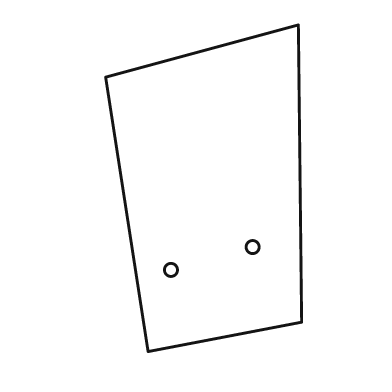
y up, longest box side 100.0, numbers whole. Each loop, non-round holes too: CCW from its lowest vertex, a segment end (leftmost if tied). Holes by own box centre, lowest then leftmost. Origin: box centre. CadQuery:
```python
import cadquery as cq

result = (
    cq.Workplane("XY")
    .moveTo(-17.0, -50.0)
    .lineTo(30.0, -41.0)
    .lineTo(29.0, 50.0)
    .lineTo(-30.0, 34.0)
    .close()
    .moveTo(-10.0, -25.0)
    .circle(2.0)
    .moveTo(15.0, -18.0)
    .circle(2.0)
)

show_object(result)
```